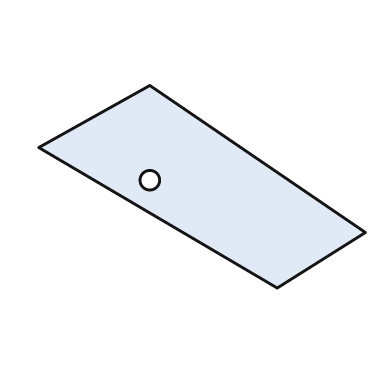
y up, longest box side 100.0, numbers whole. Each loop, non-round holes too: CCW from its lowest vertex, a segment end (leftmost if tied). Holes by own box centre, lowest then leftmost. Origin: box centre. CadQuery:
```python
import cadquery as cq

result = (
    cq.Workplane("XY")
    .moveTo(23.0, -31.0)
    .lineTo(50.0, -14.0)
    .lineTo(-16.0, 31.0)
    .lineTo(-50.0, 12.0)
    .close()
    .moveTo(-16.0, 2.0)
    .circle(3.0)
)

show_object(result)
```